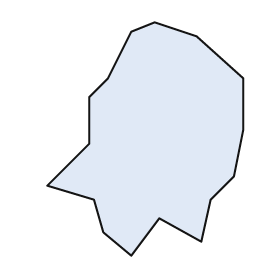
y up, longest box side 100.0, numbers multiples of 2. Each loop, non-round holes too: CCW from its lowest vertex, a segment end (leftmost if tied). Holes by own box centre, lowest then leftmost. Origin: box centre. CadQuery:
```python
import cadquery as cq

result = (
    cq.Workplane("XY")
    .moveTo(-6.0, -50.0)
    .lineTo(6.0, -34.0)
    .lineTo(24.0, -44.0)
    .lineTo(28.0, -26.0)
    .lineTo(38.0, -16.0)
    .lineTo(42.0, 4.0)
    .lineTo(42.0, 26.0)
    .lineTo(22.0, 44.0)
    .lineTo(4.0, 50.0)
    .lineTo(-6.0, 46.0)
    .lineTo(-16.0, 26.0)
    .lineTo(-24.0, 18.0)
    .lineTo(-24.0, -2.0)
    .lineTo(-42.0, -20.0)
    .lineTo(-22.0, -26.0)
    .lineTo(-18.0, -40.0)
    .close()
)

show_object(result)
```